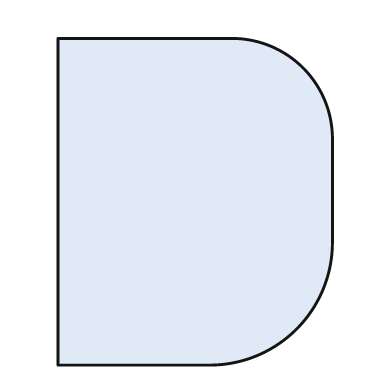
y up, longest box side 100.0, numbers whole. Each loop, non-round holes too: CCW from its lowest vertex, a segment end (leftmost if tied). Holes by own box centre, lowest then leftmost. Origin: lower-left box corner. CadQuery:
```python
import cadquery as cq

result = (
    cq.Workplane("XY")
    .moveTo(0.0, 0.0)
    .lineTo(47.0, 0.0)
    .threePointArc((73.0, 11.0), (84.0, 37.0))
    .lineTo(84.0, 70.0)
    .threePointArc((75.0, 91.0), (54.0, 100.0))
    .lineTo(0.0, 100.0)
    .close()
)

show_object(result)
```